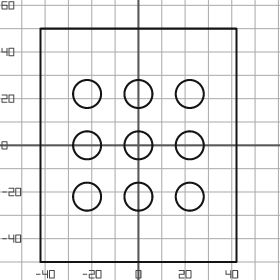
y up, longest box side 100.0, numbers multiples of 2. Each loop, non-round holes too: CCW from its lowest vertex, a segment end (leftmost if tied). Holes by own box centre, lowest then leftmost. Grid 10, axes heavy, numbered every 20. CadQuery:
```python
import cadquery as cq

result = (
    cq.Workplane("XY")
    .moveTo(-42.0, -50.0)
    .lineTo(42.0, -50.0)
    .lineTo(42.0, 50.0)
    .lineTo(-42.0, 50.0)
    .close()
    .moveTo(-22.0, -22.0)
    .circle(6.0)
    .moveTo(0.0, -22.0)
    .circle(6.0)
    .moveTo(22.0, -22.0)
    .circle(6.0)
    .moveTo(-22.0, 0.0)
    .circle(6.0)
    .moveTo(0.0, 0.0)
    .circle(6.0)
    .moveTo(22.0, 0.0)
    .circle(6.0)
    .moveTo(-22.0, 22.0)
    .circle(6.0)
    .moveTo(0.0, 22.0)
    .circle(6.0)
    .moveTo(22.0, 22.0)
    .circle(6.0)
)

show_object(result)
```